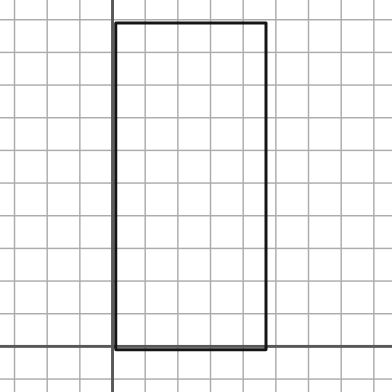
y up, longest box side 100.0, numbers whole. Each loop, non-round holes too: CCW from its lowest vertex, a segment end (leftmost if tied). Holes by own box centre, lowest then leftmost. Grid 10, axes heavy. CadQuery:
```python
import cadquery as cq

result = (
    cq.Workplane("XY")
    .moveTo(1.0, -1.0)
    .lineTo(47.0, -1.0)
    .lineTo(47.0, 99.0)
    .lineTo(1.0, 99.0)
    .close()
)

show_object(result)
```